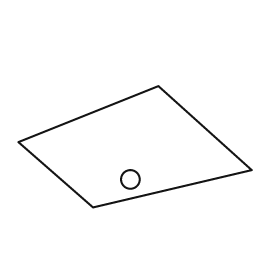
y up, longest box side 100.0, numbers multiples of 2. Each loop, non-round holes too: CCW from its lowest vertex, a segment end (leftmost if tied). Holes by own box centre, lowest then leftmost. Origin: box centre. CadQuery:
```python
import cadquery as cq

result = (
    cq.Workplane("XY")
    .moveTo(-18.0, -26.0)
    .lineTo(50.0, -10.0)
    .lineTo(10.0, 26.0)
    .lineTo(-50.0, 2.0)
    .close()
    .moveTo(-2.0, -14.0)
    .circle(4.0)
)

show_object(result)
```